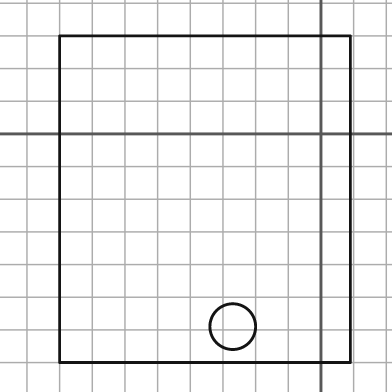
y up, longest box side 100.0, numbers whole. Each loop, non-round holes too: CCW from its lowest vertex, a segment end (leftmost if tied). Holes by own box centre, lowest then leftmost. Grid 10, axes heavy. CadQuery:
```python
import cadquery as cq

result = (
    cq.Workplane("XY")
    .moveTo(-80.0, -70.0)
    .lineTo(9.0, -70.0)
    .lineTo(9.0, 30.0)
    .lineTo(-80.0, 30.0)
    .close()
    .moveTo(-27.0, -59.0)
    .circle(7.0)
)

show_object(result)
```